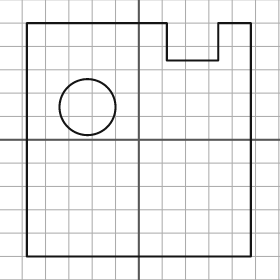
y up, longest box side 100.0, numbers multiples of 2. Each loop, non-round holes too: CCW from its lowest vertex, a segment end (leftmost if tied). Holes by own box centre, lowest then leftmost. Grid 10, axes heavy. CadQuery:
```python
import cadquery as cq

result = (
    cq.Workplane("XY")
    .moveTo(-48.0, -50.0)
    .lineTo(48.0, -50.0)
    .lineTo(48.0, 50.0)
    .lineTo(34.0, 50.0)
    .lineTo(34.0, 34.0)
    .lineTo(12.0, 34.0)
    .lineTo(12.0, 50.0)
    .lineTo(-48.0, 50.0)
    .close()
    .moveTo(-22.0, 14.0)
    .circle(12.0)
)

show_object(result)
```